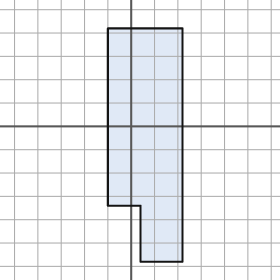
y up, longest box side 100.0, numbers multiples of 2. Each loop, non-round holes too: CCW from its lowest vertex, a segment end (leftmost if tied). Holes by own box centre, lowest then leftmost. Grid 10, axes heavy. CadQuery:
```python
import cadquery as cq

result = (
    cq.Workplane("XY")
    .moveTo(4.0, -58.0)
    .lineTo(22.0, -58.0)
    .lineTo(22.0, 42.0)
    .lineTo(-10.0, 42.0)
    .lineTo(-10.0, -34.0)
    .lineTo(4.0, -34.0)
    .close()
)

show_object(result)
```